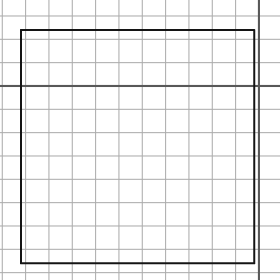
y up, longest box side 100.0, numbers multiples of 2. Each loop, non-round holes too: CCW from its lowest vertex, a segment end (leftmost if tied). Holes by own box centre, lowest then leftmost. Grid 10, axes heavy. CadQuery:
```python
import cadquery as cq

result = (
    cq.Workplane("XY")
    .moveTo(-102.0, -76.0)
    .lineTo(-2.0, -76.0)
    .lineTo(-2.0, 24.0)
    .lineTo(-102.0, 24.0)
    .close()
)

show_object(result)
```